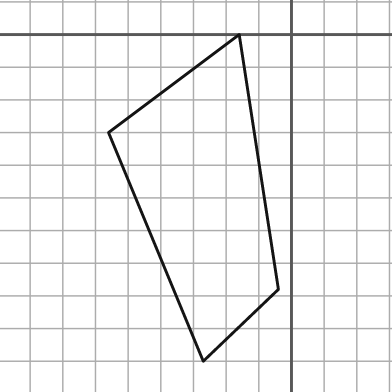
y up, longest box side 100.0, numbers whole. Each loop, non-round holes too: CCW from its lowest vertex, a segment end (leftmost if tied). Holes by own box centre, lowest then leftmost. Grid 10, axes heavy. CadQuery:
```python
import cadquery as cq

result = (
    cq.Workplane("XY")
    .moveTo(-27.0, -100.0)
    .lineTo(-4.0, -78.0)
    .lineTo(-16.0, 0.0)
    .lineTo(-56.0, -30.0)
    .close()
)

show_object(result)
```